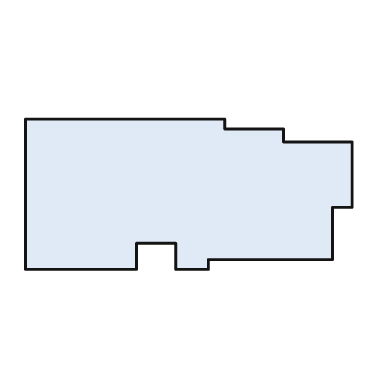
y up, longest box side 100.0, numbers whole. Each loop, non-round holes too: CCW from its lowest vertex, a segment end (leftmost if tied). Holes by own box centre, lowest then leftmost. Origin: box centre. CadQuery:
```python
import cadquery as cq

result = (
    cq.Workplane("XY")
    .moveTo(-50.0, -23.0)
    .lineTo(-16.0, -23.0)
    .lineTo(-16.0, -15.0)
    .lineTo(-4.0, -15.0)
    .lineTo(-4.0, -23.0)
    .lineTo(6.0, -23.0)
    .lineTo(6.0, -20.0)
    .lineTo(44.0, -20.0)
    .lineTo(44.0, -4.0)
    .lineTo(50.0, -4.0)
    .lineTo(50.0, 16.0)
    .lineTo(29.0, 16.0)
    .lineTo(29.0, 20.0)
    .lineTo(11.0, 20.0)
    .lineTo(11.0, 23.0)
    .lineTo(-50.0, 23.0)
    .close()
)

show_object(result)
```